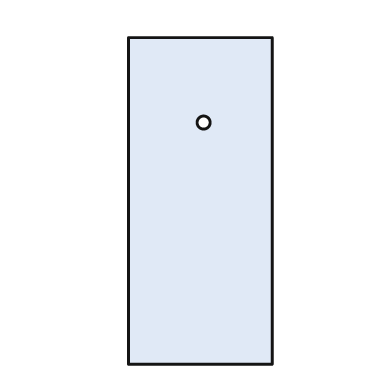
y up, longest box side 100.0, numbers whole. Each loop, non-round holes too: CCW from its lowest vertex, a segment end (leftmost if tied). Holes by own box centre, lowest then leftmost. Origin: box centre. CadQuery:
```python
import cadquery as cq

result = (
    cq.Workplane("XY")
    .moveTo(-22.0, -50.0)
    .lineTo(22.0, -50.0)
    .lineTo(22.0, 50.0)
    .lineTo(-22.0, 50.0)
    .close()
    .moveTo(1.0, 24.0)
    .circle(2.0)
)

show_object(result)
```